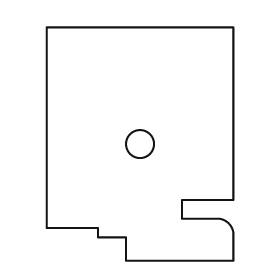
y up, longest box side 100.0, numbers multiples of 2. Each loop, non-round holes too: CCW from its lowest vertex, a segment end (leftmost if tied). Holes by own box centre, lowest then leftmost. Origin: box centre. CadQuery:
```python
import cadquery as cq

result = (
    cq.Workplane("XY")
    .moveTo(-6.0, -50.0)
    .lineTo(40.0, -50.0)
    .lineTo(40.0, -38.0)
    .threePointArc((38.0, -34.0), (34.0, -32.0))
    .lineTo(18.0, -32.0)
    .lineTo(18.0, -24.0)
    .lineTo(40.0, -24.0)
    .lineTo(40.0, 50.0)
    .lineTo(-40.0, 50.0)
    .lineTo(-40.0, -36.0)
    .lineTo(-18.0, -36.0)
    .lineTo(-18.0, -40.0)
    .lineTo(-6.0, -40.0)
    .close()
    .moveTo(0.0, 0.0)
    .circle(6.0)
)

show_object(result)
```